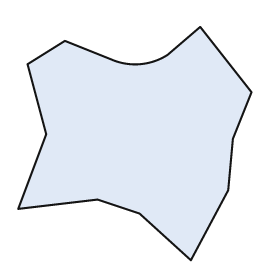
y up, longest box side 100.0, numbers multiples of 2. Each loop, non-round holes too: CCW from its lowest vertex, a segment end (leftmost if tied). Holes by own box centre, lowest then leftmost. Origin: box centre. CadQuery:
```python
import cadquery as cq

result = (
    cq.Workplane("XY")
    .moveTo(24.0, -50.0)
    .lineTo(40.0, -20.0)
    .lineTo(42.0, 2.0)
    .lineTo(50.0, 22.0)
    .lineTo(28.0, 50.0)
    .lineTo(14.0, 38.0)
    .threePointArc((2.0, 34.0), (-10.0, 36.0))
    .lineTo(-30.0, 44.0)
    .lineTo(-46.0, 34.0)
    .lineTo(-38.0, 4.0)
    .lineTo(-50.0, -28.0)
    .lineTo(-16.0, -24.0)
    .lineTo(2.0, -30.0)
    .close()
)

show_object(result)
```